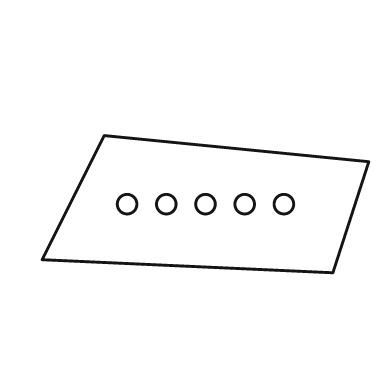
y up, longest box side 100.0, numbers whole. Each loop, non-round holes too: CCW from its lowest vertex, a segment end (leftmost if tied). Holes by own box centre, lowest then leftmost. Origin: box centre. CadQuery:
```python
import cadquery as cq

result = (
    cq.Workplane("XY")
    .moveTo(39.0, -21.0)
    .lineTo(50.0, 13.0)
    .lineTo(-31.0, 21.0)
    .lineTo(-50.0, -17.0)
    .close()
    .moveTo(-24.0, 0.0)
    .circle(3.0)
    .moveTo(-12.0, 0.0)
    .circle(3.0)
    .moveTo(0.0, 0.0)
    .circle(3.0)
    .moveTo(12.0, 0.0)
    .circle(3.0)
    .moveTo(24.0, 0.0)
    .circle(3.0)
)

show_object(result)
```